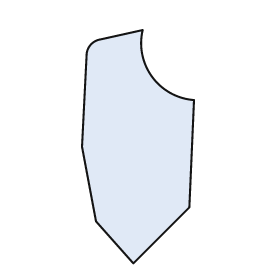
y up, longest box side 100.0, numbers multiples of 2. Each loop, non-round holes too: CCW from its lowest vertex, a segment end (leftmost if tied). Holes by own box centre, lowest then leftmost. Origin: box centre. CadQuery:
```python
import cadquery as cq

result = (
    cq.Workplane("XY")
    .moveTo(-2.0, -50.0)
    .lineTo(22.0, -26.0)
    .lineTo(24.0, 20.0)
    .threePointArc((6.0, 30.0), (2.0, 50.0))
    .lineTo(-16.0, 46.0)
    .threePointArc((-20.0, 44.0), (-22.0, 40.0))
    .lineTo(-24.0, 0.0)
    .lineTo(-18.0, -32.0)
    .close()
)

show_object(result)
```